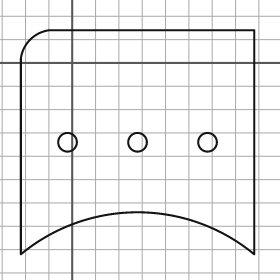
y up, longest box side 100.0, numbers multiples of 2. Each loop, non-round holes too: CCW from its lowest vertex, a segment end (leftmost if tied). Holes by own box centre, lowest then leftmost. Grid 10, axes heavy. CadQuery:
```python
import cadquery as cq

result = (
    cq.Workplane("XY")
    .moveTo(-22.0, -82.0)
    .threePointArc((28.0, -64.0), (78.0, -82.0))
    .lineTo(78.0, 14.0)
    .lineTo(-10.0, 14.0)
    .threePointArc((-18.0, 10.0), (-22.0, 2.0))
    .close()
    .moveTo(-2.0, -34.0)
    .circle(4.0)
    .moveTo(28.0, -34.0)
    .circle(4.0)
    .moveTo(58.0, -34.0)
    .circle(4.0)
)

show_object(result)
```